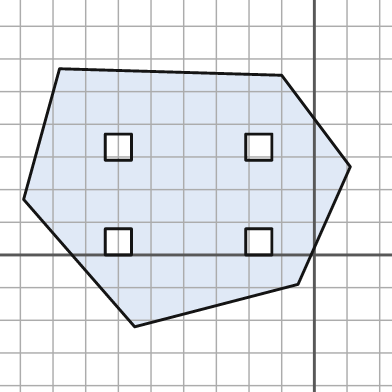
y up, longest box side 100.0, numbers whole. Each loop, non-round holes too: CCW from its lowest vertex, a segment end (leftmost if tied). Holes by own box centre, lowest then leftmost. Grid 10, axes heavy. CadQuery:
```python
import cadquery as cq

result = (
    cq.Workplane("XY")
    .moveTo(-55.0, -22.0)
    .lineTo(-5.0, -9.0)
    .lineTo(11.0, 27.0)
    .lineTo(-10.0, 55.0)
    .lineTo(-78.0, 57.0)
    .lineTo(-89.0, 17.0)
    .close()
    .moveTo(-64.0, 0.0)
    .lineTo(-56.0, 0.0)
    .lineTo(-56.0, 8.0)
    .lineTo(-64.0, 8.0)
    .close()
    .moveTo(-21.0, 0.0)
    .lineTo(-13.0, 0.0)
    .lineTo(-13.0, 8.0)
    .lineTo(-21.0, 8.0)
    .close()
    .moveTo(-64.0, 29.0)
    .lineTo(-56.0, 29.0)
    .lineTo(-56.0, 37.0)
    .lineTo(-64.0, 37.0)
    .close()
    .moveTo(-21.0, 29.0)
    .lineTo(-13.0, 29.0)
    .lineTo(-13.0, 37.0)
    .lineTo(-21.0, 37.0)
    .close()
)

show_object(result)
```